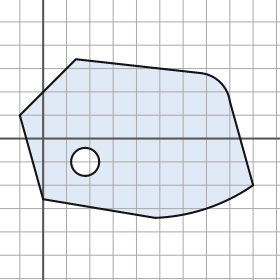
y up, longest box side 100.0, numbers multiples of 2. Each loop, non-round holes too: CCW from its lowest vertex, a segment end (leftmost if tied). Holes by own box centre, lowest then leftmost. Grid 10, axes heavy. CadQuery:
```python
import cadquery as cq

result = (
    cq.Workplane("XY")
    .moveTo(48.0, -34.0)
    .threePointArc((70.0, -30.0), (90.0, -20.0))
    .lineTo(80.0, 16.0)
    .threePointArc((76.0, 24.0), (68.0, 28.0))
    .lineTo(14.0, 34.0)
    .lineTo(-10.0, 10.0)
    .lineTo(0.0, -26.0)
    .close()
    .moveTo(18.0, -10.0)
    .circle(6.0)
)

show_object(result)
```